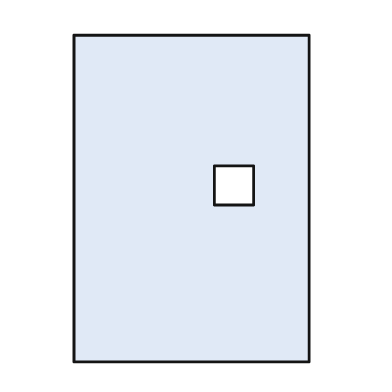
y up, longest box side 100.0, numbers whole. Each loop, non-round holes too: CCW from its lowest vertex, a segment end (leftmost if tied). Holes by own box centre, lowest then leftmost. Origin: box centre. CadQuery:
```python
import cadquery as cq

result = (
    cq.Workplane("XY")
    .moveTo(-36.0, -50.0)
    .lineTo(36.0, -50.0)
    .lineTo(36.0, 50.0)
    .lineTo(-36.0, 50.0)
    .close()
    .moveTo(7.0, -2.0)
    .lineTo(19.0, -2.0)
    .lineTo(19.0, 10.0)
    .lineTo(7.0, 10.0)
    .close()
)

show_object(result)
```